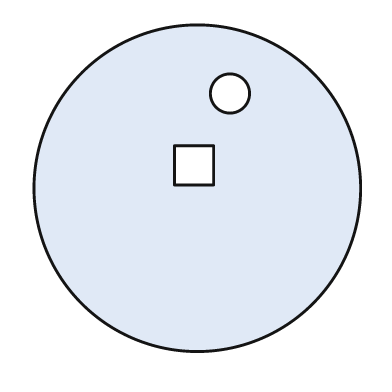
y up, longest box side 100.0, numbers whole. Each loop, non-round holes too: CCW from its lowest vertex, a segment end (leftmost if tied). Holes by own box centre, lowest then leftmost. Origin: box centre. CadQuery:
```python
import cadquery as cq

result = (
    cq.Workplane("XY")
    .moveTo(0.0, 0.0)
    .circle(50.0)
    .moveTo(-7.0, 1.0)
    .lineTo(5.0, 1.0)
    .lineTo(5.0, 13.0)
    .lineTo(-7.0, 13.0)
    .close()
    .moveTo(10.0, 29.0)
    .circle(6.0)
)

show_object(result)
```